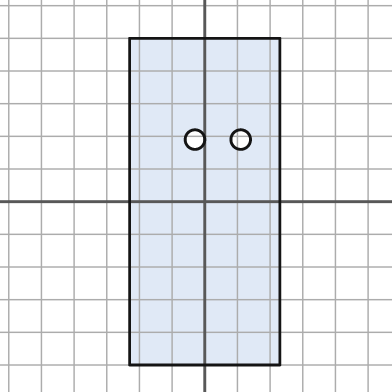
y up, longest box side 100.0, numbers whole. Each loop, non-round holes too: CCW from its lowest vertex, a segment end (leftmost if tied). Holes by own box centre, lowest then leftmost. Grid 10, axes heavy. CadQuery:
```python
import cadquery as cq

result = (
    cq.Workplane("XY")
    .moveTo(-23.0, -50.0)
    .lineTo(23.0, -50.0)
    .lineTo(23.0, 50.0)
    .lineTo(-23.0, 50.0)
    .close()
    .moveTo(-3.0, 19.0)
    .circle(3.0)
    .moveTo(11.0, 19.0)
    .circle(3.0)
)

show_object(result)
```